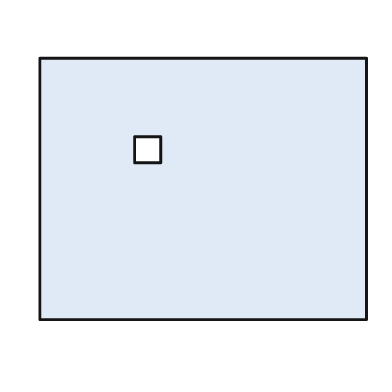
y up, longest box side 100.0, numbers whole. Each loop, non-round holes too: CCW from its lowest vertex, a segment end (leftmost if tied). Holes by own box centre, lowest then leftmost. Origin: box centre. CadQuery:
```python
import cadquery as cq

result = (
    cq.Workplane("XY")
    .moveTo(-50.0, -40.0)
    .lineTo(50.0, -40.0)
    .lineTo(50.0, 40.0)
    .lineTo(-50.0, 40.0)
    .close()
    .moveTo(-21.0, 8.0)
    .lineTo(-13.0, 8.0)
    .lineTo(-13.0, 16.0)
    .lineTo(-21.0, 16.0)
    .close()
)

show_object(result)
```